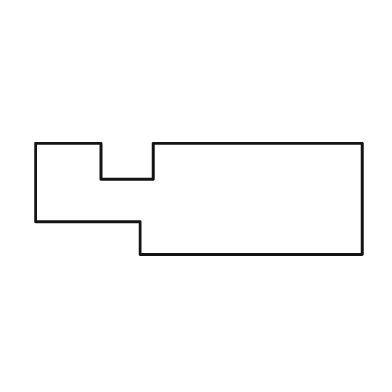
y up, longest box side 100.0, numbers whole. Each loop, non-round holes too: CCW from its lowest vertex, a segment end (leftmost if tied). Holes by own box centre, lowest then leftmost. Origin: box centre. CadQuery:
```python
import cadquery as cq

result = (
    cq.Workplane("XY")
    .moveTo(-18.0, -17.0)
    .lineTo(50.0, -17.0)
    .lineTo(50.0, 17.0)
    .lineTo(-14.0, 17.0)
    .lineTo(-14.0, 6.0)
    .lineTo(-30.0, 6.0)
    .lineTo(-30.0, 17.0)
    .lineTo(-50.0, 17.0)
    .lineTo(-50.0, -7.0)
    .lineTo(-18.0, -7.0)
    .close()
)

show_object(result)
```